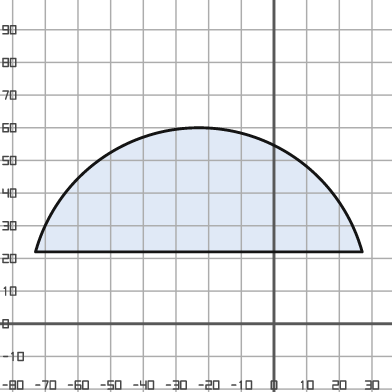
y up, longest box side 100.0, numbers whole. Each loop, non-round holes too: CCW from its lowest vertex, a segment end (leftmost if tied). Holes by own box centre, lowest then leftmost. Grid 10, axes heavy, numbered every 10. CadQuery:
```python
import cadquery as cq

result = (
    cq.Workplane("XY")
    .moveTo(-73.0, 22.0)
    .lineTo(27.0, 22.0)
    .threePointArc((-23.0, 60.0), (-73.0, 22.0))
    .close()
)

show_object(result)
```